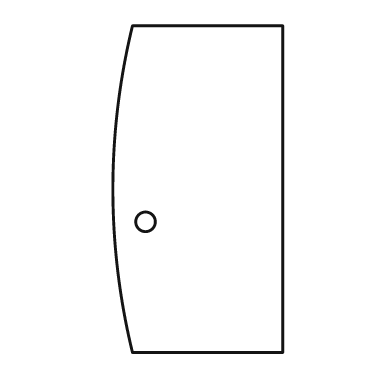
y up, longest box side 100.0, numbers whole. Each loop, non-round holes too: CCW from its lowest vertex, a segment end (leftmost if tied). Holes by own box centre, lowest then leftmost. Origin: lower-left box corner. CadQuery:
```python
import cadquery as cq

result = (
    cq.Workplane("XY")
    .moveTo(6.0, 0.0)
    .lineTo(52.0, 0.0)
    .lineTo(52.0, 100.0)
    .lineTo(6.0, 100.0)
    .threePointArc((0.0, 50.0), (6.0, 0.0))
    .close()
    .moveTo(10.0, 40.0)
    .circle(3.0)
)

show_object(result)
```